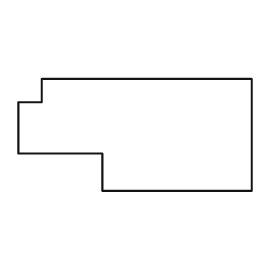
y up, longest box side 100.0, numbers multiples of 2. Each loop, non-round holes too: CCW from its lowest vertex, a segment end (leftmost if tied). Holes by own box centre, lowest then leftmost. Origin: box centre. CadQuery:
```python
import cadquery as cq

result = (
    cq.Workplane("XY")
    .moveTo(-14.0, -24.0)
    .lineTo(50.0, -24.0)
    .lineTo(50.0, 24.0)
    .lineTo(-40.0, 24.0)
    .lineTo(-40.0, 14.0)
    .lineTo(-50.0, 14.0)
    .lineTo(-50.0, -8.0)
    .lineTo(-14.0, -8.0)
    .close()
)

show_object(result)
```